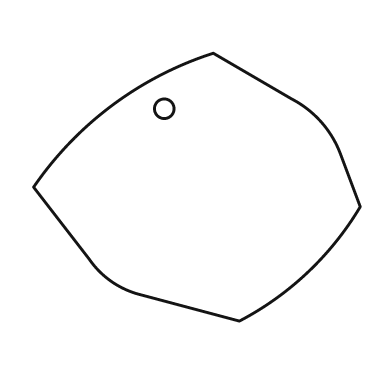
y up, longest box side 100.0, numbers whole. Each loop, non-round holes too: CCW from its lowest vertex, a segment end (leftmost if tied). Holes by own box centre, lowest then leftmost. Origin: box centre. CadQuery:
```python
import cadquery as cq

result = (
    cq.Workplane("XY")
    .moveTo(13.0, -41.0)
    .threePointArc((34.0, -26.0), (50.0, -6.0))
    .lineTo(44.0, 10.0)
    .threePointArc((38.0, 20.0), (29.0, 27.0))
    .lineTo(5.0, 41.0)
    .threePointArc((-26.0, 25.0), (-50.0, 0.0))
    .lineTo(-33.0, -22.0)
    .threePointArc((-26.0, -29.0), (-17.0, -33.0))
    .close()
    .moveTo(-10.0, 24.0)
    .circle(3.0)
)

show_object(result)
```